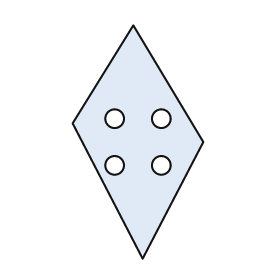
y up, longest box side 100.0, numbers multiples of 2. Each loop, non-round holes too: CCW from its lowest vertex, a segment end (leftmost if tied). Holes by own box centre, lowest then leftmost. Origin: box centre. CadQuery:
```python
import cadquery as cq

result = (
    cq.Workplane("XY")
    .moveTo(2.0, -50.0)
    .lineTo(28.0, 0.0)
    .lineTo(-2.0, 50.0)
    .lineTo(-28.0, 8.0)
    .close()
    .moveTo(-10.0, -10.0)
    .circle(4.0)
    .moveTo(10.0, -10.0)
    .circle(4.0)
    .moveTo(-10.0, 10.0)
    .circle(4.0)
    .moveTo(10.0, 10.0)
    .circle(4.0)
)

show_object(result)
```